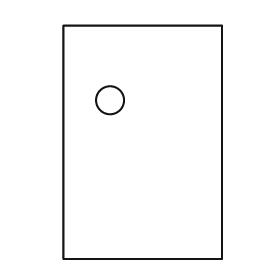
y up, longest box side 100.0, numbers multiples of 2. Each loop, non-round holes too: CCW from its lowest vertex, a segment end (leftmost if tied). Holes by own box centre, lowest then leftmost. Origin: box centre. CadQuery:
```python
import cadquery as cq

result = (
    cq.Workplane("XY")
    .moveTo(-34.0, -50.0)
    .lineTo(34.0, -50.0)
    .lineTo(34.0, 50.0)
    .lineTo(-34.0, 50.0)
    .close()
    .moveTo(-14.0, 18.0)
    .circle(6.0)
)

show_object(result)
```